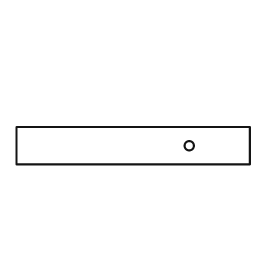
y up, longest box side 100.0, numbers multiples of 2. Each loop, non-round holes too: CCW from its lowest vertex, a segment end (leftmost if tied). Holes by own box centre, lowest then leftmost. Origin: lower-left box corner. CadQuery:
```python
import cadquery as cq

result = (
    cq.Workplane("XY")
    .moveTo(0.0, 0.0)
    .lineTo(100.0, 0.0)
    .lineTo(100.0, 16.0)
    .lineTo(0.0, 16.0)
    .close()
    .moveTo(74.0, 8.0)
    .circle(2.0)
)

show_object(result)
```